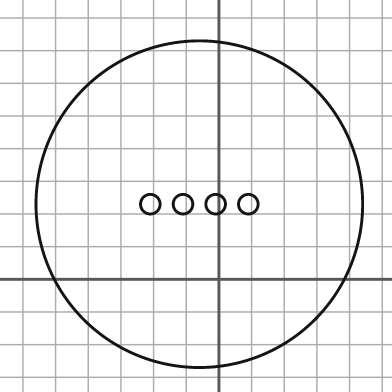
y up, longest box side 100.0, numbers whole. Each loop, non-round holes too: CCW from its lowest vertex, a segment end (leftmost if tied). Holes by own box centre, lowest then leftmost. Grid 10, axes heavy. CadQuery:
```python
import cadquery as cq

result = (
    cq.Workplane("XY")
    .moveTo(-6.0, 23.0)
    .circle(50.0)
    .moveTo(-21.0, 23.0)
    .circle(3.0)
    .moveTo(-11.0, 23.0)
    .circle(3.0)
    .moveTo(-1.0, 23.0)
    .circle(3.0)
    .moveTo(9.0, 23.0)
    .circle(3.0)
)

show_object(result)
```